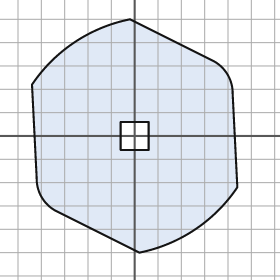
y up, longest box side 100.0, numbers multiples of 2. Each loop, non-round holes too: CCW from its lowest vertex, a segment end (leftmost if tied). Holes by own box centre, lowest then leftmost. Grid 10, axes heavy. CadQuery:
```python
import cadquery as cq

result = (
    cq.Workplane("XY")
    .moveTo(2.0, -50.0)
    .threePointArc((26.0, -40.0), (44.0, -22.0))
    .lineTo(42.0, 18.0)
    .threePointArc((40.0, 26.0), (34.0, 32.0))
    .lineTo(-2.0, 50.0)
    .threePointArc((-26.0, 40.0), (-44.0, 22.0))
    .lineTo(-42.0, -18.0)
    .threePointArc((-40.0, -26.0), (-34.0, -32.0))
    .close()
    .moveTo(-6.0, -6.0)
    .lineTo(6.0, -6.0)
    .lineTo(6.0, 6.0)
    .lineTo(-6.0, 6.0)
    .close()
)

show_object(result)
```